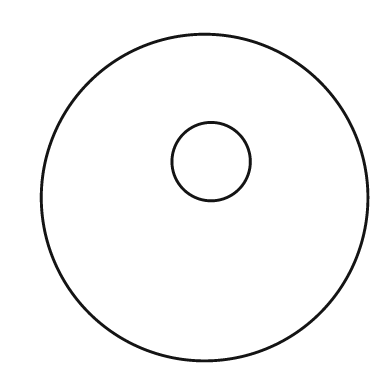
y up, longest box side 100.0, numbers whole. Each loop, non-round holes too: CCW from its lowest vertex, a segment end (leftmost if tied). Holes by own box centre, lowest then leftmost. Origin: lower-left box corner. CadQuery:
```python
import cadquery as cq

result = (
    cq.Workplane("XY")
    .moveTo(50.0, 50.0)
    .circle(50.0)
    .moveTo(52.0, 61.0)
    .circle(12.0)
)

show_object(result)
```